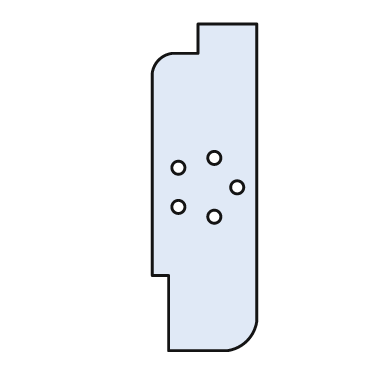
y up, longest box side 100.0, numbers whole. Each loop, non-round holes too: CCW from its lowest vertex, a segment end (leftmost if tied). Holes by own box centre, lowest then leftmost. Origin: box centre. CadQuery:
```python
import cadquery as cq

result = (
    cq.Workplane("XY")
    .moveTo(-11.0, -50.0)
    .lineTo(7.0, -50.0)
    .threePointArc((13.0, -47.0), (16.0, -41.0))
    .lineTo(16.0, 50.0)
    .lineTo(-2.0, 50.0)
    .lineTo(-2.0, 41.0)
    .lineTo(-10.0, 41.0)
    .threePointArc((-14.0, 39.0), (-16.0, 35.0))
    .lineTo(-16.0, -27.0)
    .lineTo(-11.0, -27.0)
    .close()
    .moveTo(3.0, -9.0)
    .circle(2.0)
    .moveTo(-8.0, -6.0)
    .circle(2.0)
    .moveTo(10.0, 0.0)
    .circle(2.0)
    .moveTo(-8.0, 6.0)
    .circle(2.0)
    .moveTo(3.0, 9.0)
    .circle(2.0)
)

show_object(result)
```